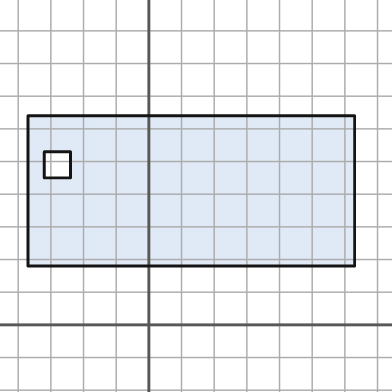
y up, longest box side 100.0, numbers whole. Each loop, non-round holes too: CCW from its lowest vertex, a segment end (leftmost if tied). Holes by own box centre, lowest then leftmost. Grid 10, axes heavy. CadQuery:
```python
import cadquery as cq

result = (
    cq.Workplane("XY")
    .moveTo(-37.0, 18.0)
    .lineTo(63.0, 18.0)
    .lineTo(63.0, 64.0)
    .lineTo(-37.0, 64.0)
    .close()
    .moveTo(-32.0, 45.0)
    .lineTo(-24.0, 45.0)
    .lineTo(-24.0, 53.0)
    .lineTo(-32.0, 53.0)
    .close()
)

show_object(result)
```